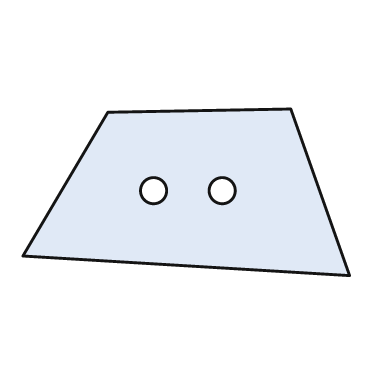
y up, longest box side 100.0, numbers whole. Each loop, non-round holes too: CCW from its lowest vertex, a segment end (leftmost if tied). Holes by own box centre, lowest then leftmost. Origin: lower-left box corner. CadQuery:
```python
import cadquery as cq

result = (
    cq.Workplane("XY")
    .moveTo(100.0, 0.0)
    .lineTo(82.0, 51.0)
    .lineTo(26.0, 50.0)
    .lineTo(0.0, 6.0)
    .close()
    .moveTo(40.0, 26.0)
    .circle(4.0)
    .moveTo(61.0, 26.0)
    .circle(4.0)
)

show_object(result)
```